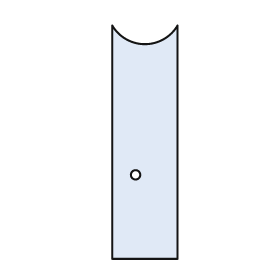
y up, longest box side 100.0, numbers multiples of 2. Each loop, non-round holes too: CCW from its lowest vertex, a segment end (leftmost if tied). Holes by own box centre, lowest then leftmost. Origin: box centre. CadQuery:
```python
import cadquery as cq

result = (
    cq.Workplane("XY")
    .moveTo(-14.0, -50.0)
    .lineTo(14.0, -50.0)
    .lineTo(14.0, 50.0)
    .threePointArc((0.0, 42.0), (-14.0, 50.0))
    .close()
    .moveTo(-4.0, -14.0)
    .circle(2.0)
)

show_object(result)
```